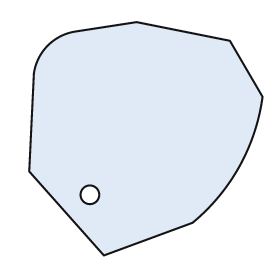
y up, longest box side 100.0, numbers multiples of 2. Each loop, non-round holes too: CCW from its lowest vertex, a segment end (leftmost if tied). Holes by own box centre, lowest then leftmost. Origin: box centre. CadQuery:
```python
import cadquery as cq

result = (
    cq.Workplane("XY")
    .moveTo(-18.0, -50.0)
    .lineTo(20.0, -36.0)
    .threePointArc((40.0, -12.0), (50.0, 18.0))
    .lineTo(36.0, 42.0)
    .lineTo(-4.0, 50.0)
    .lineTo(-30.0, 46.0)
    .threePointArc((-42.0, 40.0), (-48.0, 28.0))
    .lineTo(-50.0, -14.0)
    .close()
    .moveTo(-24.0, -24.0)
    .circle(4.0)
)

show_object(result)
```